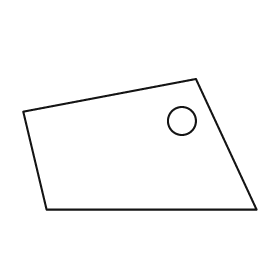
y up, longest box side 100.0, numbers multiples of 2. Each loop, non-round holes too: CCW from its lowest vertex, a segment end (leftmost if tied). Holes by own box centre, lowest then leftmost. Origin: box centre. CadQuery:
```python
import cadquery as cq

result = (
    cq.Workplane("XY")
    .moveTo(-40.0, -28.0)
    .lineTo(50.0, -28.0)
    .lineTo(24.0, 28.0)
    .lineTo(-50.0, 14.0)
    .close()
    .moveTo(18.0, 10.0)
    .circle(6.0)
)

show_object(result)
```